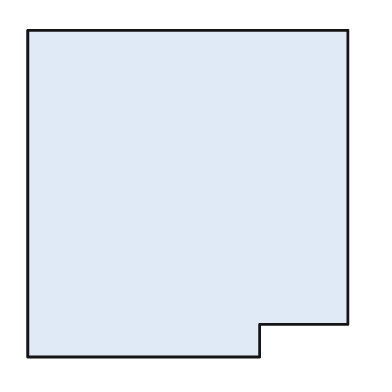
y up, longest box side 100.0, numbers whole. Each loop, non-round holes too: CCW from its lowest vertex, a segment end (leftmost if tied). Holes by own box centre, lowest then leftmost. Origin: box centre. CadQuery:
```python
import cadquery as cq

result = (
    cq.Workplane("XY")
    .moveTo(-49.0, -50.0)
    .lineTo(22.0, -50.0)
    .lineTo(22.0, -40.0)
    .lineTo(49.0, -40.0)
    .lineTo(49.0, 50.0)
    .lineTo(-49.0, 50.0)
    .close()
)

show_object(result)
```